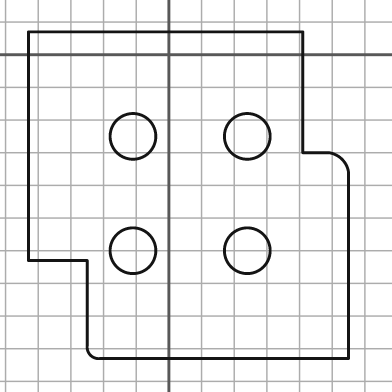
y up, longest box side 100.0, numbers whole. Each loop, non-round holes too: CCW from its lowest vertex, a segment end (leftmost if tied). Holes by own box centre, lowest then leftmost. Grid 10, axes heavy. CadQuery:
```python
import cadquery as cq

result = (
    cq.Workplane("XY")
    .moveTo(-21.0, -93.0)
    .lineTo(55.0, -93.0)
    .lineTo(55.0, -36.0)
    .threePointArc((53.0, -32.0), (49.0, -30.0))
    .lineTo(41.0, -30.0)
    .lineTo(41.0, 7.0)
    .lineTo(-43.0, 7.0)
    .lineTo(-43.0, -63.0)
    .lineTo(-25.0, -63.0)
    .lineTo(-25.0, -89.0)
    .threePointArc((-24.0, -92.0), (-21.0, -93.0))
    .close()
    .moveTo(-11.0, -60.0)
    .circle(7.0)
    .moveTo(24.0, -60.0)
    .circle(7.0)
    .moveTo(-11.0, -25.0)
    .circle(7.0)
    .moveTo(24.0, -25.0)
    .circle(7.0)
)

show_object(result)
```